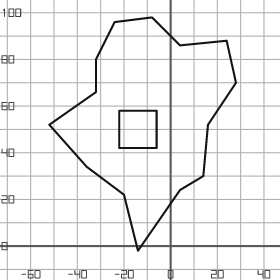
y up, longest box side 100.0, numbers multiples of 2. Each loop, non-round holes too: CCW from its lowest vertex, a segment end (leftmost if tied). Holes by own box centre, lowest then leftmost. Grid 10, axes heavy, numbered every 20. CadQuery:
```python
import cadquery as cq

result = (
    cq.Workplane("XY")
    .moveTo(-14.0, -2.0)
    .lineTo(4.0, 24.0)
    .lineTo(14.0, 30.0)
    .lineTo(16.0, 52.0)
    .lineTo(28.0, 70.0)
    .lineTo(24.0, 88.0)
    .lineTo(4.0, 86.0)
    .lineTo(-8.0, 98.0)
    .lineTo(-24.0, 96.0)
    .lineTo(-32.0, 80.0)
    .lineTo(-32.0, 66.0)
    .lineTo(-52.0, 52.0)
    .lineTo(-36.0, 34.0)
    .lineTo(-20.0, 22.0)
    .close()
    .moveTo(-22.0, 42.0)
    .lineTo(-6.0, 42.0)
    .lineTo(-6.0, 58.0)
    .lineTo(-22.0, 58.0)
    .close()
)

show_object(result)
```